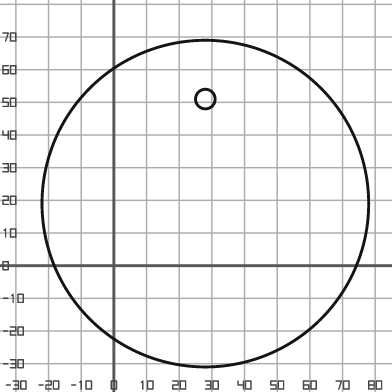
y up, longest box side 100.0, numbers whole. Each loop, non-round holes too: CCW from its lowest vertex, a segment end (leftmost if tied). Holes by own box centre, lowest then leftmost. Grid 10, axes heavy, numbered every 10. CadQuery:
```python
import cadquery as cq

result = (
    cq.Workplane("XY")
    .moveTo(28.0, 19.0)
    .circle(50.0)
    .moveTo(28.0, 51.0)
    .circle(3.0)
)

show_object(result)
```